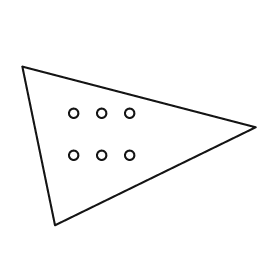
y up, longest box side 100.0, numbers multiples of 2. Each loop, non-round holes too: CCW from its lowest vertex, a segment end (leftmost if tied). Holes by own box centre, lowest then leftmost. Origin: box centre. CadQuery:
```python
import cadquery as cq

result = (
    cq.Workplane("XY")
    .moveTo(-36.0, -34.0)
    .lineTo(50.0, 8.0)
    .lineTo(-50.0, 34.0)
    .close()
    .moveTo(-28.0, -4.0)
    .circle(2.0)
    .moveTo(-16.0, -4.0)
    .circle(2.0)
    .moveTo(-4.0, -4.0)
    .circle(2.0)
    .moveTo(-28.0, 14.0)
    .circle(2.0)
    .moveTo(-16.0, 14.0)
    .circle(2.0)
    .moveTo(-4.0, 14.0)
    .circle(2.0)
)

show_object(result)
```